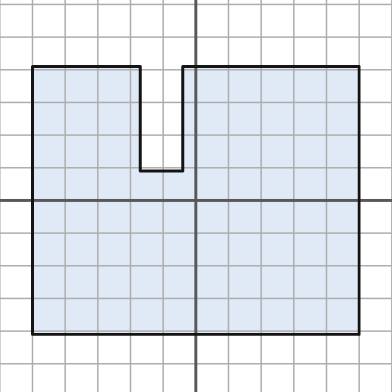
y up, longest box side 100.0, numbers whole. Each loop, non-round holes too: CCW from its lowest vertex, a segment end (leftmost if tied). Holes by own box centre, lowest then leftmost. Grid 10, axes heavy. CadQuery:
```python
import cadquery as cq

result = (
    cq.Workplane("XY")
    .moveTo(-50.0, -41.0)
    .lineTo(50.0, -41.0)
    .lineTo(50.0, 41.0)
    .lineTo(-4.0, 41.0)
    .lineTo(-4.0, 9.0)
    .lineTo(-17.0, 9.0)
    .lineTo(-17.0, 41.0)
    .lineTo(-50.0, 41.0)
    .close()
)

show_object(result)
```